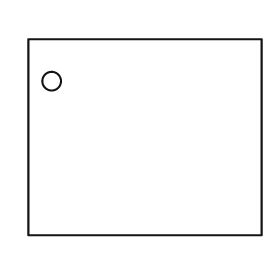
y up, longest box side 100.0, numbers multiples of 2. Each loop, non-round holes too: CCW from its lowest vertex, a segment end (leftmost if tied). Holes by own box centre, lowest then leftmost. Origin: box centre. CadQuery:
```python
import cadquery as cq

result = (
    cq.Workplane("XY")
    .moveTo(-50.0, -42.0)
    .lineTo(50.0, -42.0)
    .lineTo(50.0, 42.0)
    .lineTo(-50.0, 42.0)
    .close()
    .moveTo(-40.0, 24.0)
    .circle(4.0)
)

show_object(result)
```